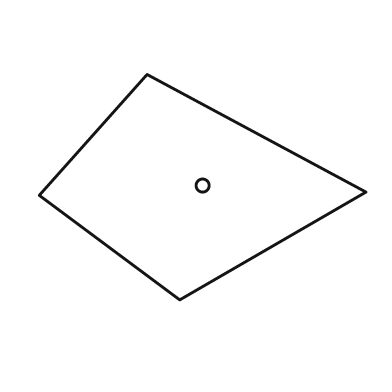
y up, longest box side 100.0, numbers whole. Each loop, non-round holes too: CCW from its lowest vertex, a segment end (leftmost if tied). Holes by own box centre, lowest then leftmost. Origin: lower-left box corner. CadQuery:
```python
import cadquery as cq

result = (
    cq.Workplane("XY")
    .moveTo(43.0, 0.0)
    .lineTo(100.0, 33.0)
    .lineTo(33.0, 69.0)
    .lineTo(0.0, 32.0)
    .close()
    .moveTo(50.0, 35.0)
    .circle(2.0)
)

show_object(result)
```